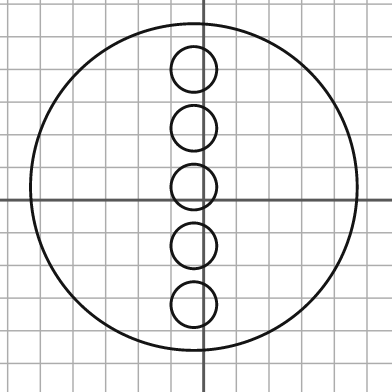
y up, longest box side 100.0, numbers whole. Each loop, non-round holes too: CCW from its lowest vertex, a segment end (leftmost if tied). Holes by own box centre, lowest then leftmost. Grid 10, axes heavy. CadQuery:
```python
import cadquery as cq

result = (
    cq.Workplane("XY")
    .moveTo(-3.0, 4.0)
    .circle(50.0)
    .moveTo(-3.0, -32.0)
    .circle(7.0)
    .moveTo(-3.0, -14.0)
    .circle(7.0)
    .moveTo(-3.0, 4.0)
    .circle(7.0)
    .moveTo(-3.0, 22.0)
    .circle(7.0)
    .moveTo(-3.0, 40.0)
    .circle(7.0)
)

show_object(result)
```